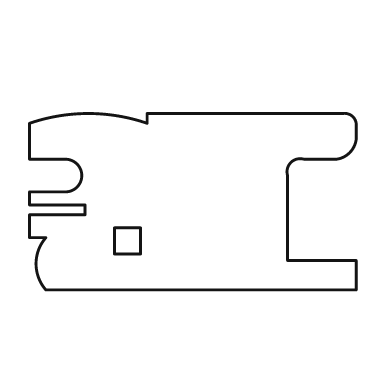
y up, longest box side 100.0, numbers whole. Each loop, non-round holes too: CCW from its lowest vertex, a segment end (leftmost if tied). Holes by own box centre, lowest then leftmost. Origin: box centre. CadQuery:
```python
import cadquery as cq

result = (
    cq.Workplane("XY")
    .moveTo(-45.0, -27.0)
    .lineTo(50.0, -27.0)
    .lineTo(50.0, -18.0)
    .lineTo(29.0, -18.0)
    .lineTo(29.0, 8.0)
    .threePointArc((30.0, 12.0), (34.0, 13.0))
    .lineTo(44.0, 13.0)
    .threePointArc((48.0, 15.0), (50.0, 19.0))
    .lineTo(50.0, 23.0)
    .threePointArc((49.0, 26.0), (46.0, 27.0))
    .lineTo(-14.0, 27.0)
    .lineTo(-14.0, 24.0)
    .threePointArc((-32.0, 27.0), (-50.0, 24.0))
    .lineTo(-50.0, 13.0)
    .lineTo(-39.0, 13.0)
    .threePointArc((-34.0, 8.0), (-39.0, 3.0))
    .lineTo(-50.0, 3.0)
    .lineTo(-50.0, -1.0)
    .lineTo(-33.0, -1.0)
    .lineTo(-33.0, -4.0)
    .lineTo(-50.0, -4.0)
    .lineTo(-50.0, -11.0)
    .lineTo(-45.0, -11.0)
    .threePointArc((-48.0, -19.0), (-45.0, -27.0))
    .close()
    .moveTo(-24.0, -16.0)
    .lineTo(-16.0, -16.0)
    .lineTo(-16.0, -8.0)
    .lineTo(-24.0, -8.0)
    .close()
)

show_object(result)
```